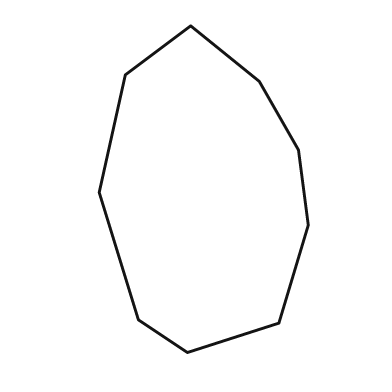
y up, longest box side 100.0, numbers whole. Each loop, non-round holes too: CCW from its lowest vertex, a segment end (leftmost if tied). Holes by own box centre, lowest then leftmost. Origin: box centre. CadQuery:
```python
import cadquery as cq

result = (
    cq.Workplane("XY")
    .moveTo(-5.0, -50.0)
    .lineTo(23.0, -41.0)
    .lineTo(32.0, -11.0)
    .lineTo(29.0, 12.0)
    .lineTo(17.0, 33.0)
    .lineTo(-4.0, 50.0)
    .lineTo(-24.0, 35.0)
    .lineTo(-32.0, -1.0)
    .lineTo(-20.0, -40.0)
    .close()
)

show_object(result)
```